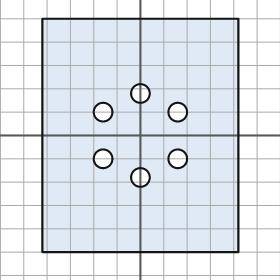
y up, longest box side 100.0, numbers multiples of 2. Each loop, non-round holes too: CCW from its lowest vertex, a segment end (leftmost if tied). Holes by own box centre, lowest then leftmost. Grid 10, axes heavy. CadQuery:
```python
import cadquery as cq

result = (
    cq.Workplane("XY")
    .moveTo(-42.0, -50.0)
    .lineTo(42.0, -50.0)
    .lineTo(42.0, 50.0)
    .lineTo(-42.0, 50.0)
    .close()
    .moveTo(0.0, -18.0)
    .circle(4.0)
    .moveTo(-16.0, -10.0)
    .circle(4.0)
    .moveTo(16.0, -10.0)
    .circle(4.0)
    .moveTo(-16.0, 10.0)
    .circle(4.0)
    .moveTo(16.0, 10.0)
    .circle(4.0)
    .moveTo(0.0, 18.0)
    .circle(4.0)
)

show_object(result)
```